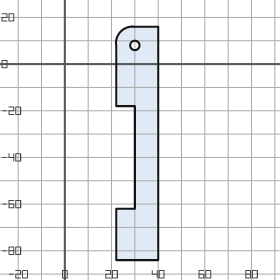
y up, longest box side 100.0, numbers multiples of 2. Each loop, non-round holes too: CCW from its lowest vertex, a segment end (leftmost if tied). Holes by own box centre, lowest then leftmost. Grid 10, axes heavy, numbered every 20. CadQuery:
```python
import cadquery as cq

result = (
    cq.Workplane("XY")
    .moveTo(22.0, -84.0)
    .lineTo(40.0, -84.0)
    .lineTo(40.0, 16.0)
    .lineTo(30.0, 16.0)
    .threePointArc((24.0, 14.0), (22.0, 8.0))
    .lineTo(22.0, -18.0)
    .lineTo(30.0, -18.0)
    .lineTo(30.0, -62.0)
    .lineTo(22.0, -62.0)
    .close()
    .moveTo(30.0, 8.0)
    .circle(2.0)
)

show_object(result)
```